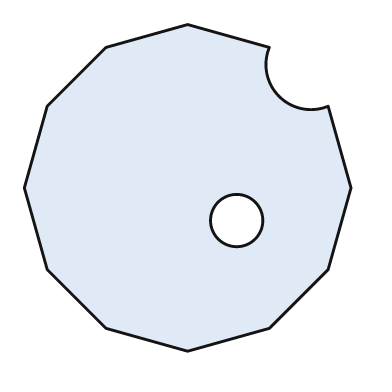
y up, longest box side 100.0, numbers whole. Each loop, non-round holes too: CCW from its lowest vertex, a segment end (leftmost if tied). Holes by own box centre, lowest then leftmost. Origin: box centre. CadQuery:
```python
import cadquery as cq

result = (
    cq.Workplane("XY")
    .moveTo(0.0, -50.0)
    .lineTo(25.0, -43.0)
    .lineTo(43.0, -25.0)
    .lineTo(50.0, 0.0)
    .lineTo(43.0, 25.0)
    .threePointArc((28.0, 28.0), (25.0, 43.0))
    .lineTo(0.0, 50.0)
    .lineTo(-25.0, 43.0)
    .lineTo(-43.0, 25.0)
    .lineTo(-50.0, 0.0)
    .lineTo(-43.0, -25.0)
    .lineTo(-25.0, -43.0)
    .close()
    .moveTo(15.0, -10.0)
    .circle(8.0)
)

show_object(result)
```